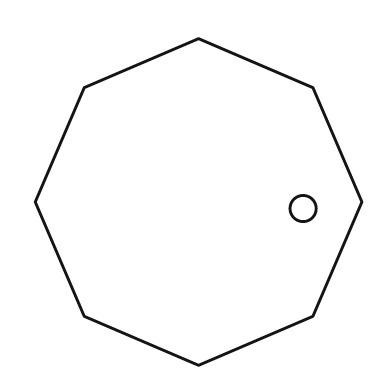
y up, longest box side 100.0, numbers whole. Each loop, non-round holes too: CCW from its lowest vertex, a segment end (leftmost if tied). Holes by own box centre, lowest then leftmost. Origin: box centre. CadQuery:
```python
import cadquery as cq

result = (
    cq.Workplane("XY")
    .moveTo(0.0, -50.0)
    .lineTo(35.0, -35.0)
    .lineTo(50.0, 0.0)
    .lineTo(35.0, 35.0)
    .lineTo(0.0, 50.0)
    .lineTo(-35.0, 35.0)
    .lineTo(-50.0, 0.0)
    .lineTo(-35.0, -35.0)
    .close()
    .moveTo(32.0, -2.0)
    .circle(4.0)
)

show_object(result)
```